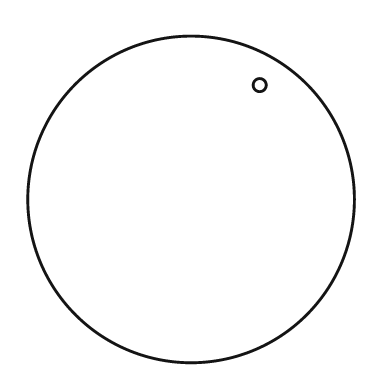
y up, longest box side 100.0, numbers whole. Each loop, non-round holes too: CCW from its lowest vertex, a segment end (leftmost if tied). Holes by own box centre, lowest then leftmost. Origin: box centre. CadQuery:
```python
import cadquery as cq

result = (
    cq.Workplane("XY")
    .moveTo(0.0, 0.0)
    .circle(50.0)
    .moveTo(21.0, 35.0)
    .circle(2.0)
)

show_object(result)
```